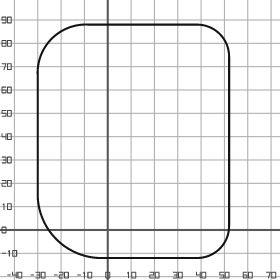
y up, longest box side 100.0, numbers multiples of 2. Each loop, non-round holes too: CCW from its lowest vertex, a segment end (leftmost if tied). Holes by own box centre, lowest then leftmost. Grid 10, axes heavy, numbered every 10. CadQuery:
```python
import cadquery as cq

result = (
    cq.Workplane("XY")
    .moveTo(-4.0, -12.0)
    .lineTo(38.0, -12.0)
    .threePointArc((48.0, -8.0), (52.0, 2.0))
    .lineTo(52.0, 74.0)
    .threePointArc((48.0, 84.0), (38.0, 88.0))
    .lineTo(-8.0, 88.0)
    .threePointArc((-24.0, 82.0), (-30.0, 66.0))
    .lineTo(-30.0, 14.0)
    .threePointArc((-22.0, -4.0), (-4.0, -12.0))
    .close()
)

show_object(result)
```